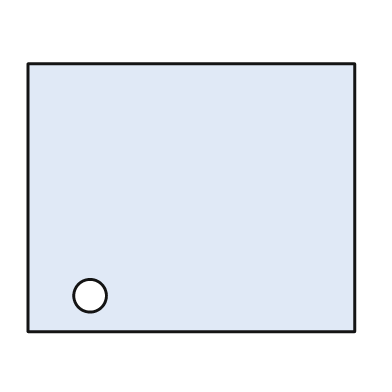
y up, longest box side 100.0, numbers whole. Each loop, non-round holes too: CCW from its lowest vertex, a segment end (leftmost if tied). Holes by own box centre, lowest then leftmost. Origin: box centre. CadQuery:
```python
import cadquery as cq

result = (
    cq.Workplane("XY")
    .moveTo(-50.0, -41.0)
    .lineTo(50.0, -41.0)
    .lineTo(50.0, 41.0)
    .lineTo(-50.0, 41.0)
    .close()
    .moveTo(-31.0, -30.0)
    .circle(5.0)
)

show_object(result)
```